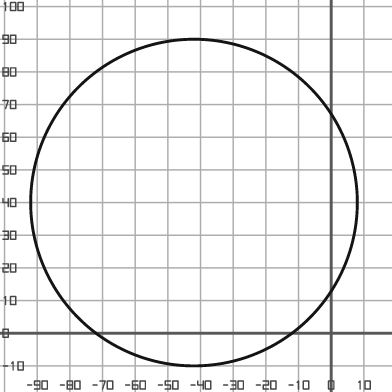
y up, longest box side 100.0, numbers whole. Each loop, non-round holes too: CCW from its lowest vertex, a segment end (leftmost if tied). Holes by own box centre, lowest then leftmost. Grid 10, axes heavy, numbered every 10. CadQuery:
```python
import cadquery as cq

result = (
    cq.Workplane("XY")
    .moveTo(-42.0, 40.0)
    .circle(50.0)
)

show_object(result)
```